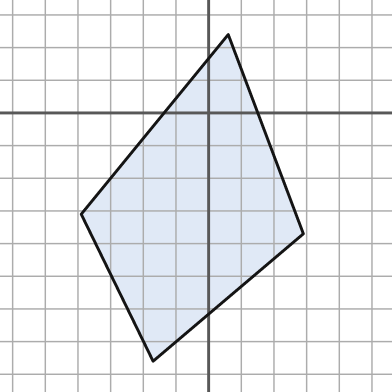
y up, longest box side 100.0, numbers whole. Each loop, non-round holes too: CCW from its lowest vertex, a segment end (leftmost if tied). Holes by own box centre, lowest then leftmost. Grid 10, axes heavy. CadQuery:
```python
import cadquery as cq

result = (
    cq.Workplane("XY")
    .moveTo(-17.0, -76.0)
    .lineTo(29.0, -37.0)
    .lineTo(6.0, 24.0)
    .lineTo(-39.0, -31.0)
    .close()
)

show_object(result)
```